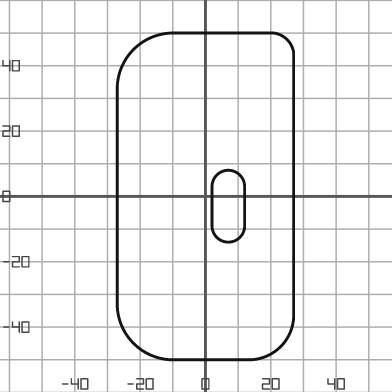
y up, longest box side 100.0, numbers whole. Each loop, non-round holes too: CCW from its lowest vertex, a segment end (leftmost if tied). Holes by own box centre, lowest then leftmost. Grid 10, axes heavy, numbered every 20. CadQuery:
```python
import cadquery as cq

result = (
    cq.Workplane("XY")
    .moveTo(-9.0, -50.0)
    .lineTo(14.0, -50.0)
    .threePointArc((23.0, -46.0), (27.0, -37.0))
    .lineTo(27.0, 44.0)
    .threePointArc((25.0, 48.0), (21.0, 50.0))
    .lineTo(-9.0, 50.0)
    .threePointArc((-22.0, 45.0), (-27.0, 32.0))
    .lineTo(-27.0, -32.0)
    .threePointArc((-22.0, -45.0), (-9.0, -50.0))
    .close()
    .moveTo(2.0, -9.0)
    .threePointArc((7.0, -14.0), (12.0, -9.0))
    .lineTo(12.0, 3.0)
    .threePointArc((7.0, 8.0), (2.0, 3.0))
    .close()
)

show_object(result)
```